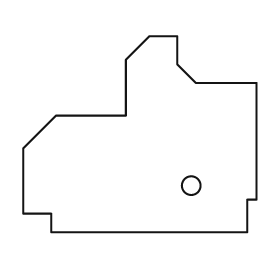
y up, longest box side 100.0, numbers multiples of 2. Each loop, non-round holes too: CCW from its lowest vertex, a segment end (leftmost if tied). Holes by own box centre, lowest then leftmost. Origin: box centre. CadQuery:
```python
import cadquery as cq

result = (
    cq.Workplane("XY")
    .moveTo(-38.0, -42.0)
    .lineTo(46.0, -42.0)
    .lineTo(46.0, -28.0)
    .lineTo(50.0, -28.0)
    .lineTo(50.0, 22.0)
    .lineTo(24.0, 22.0)
    .lineTo(16.0, 30.0)
    .lineTo(16.0, 42.0)
    .lineTo(4.0, 42.0)
    .lineTo(-6.0, 32.0)
    .lineTo(-6.0, 8.0)
    .lineTo(-36.0, 8.0)
    .lineTo(-50.0, -6.0)
    .lineTo(-50.0, -34.0)
    .lineTo(-38.0, -34.0)
    .close()
    .moveTo(22.0, -22.0)
    .circle(4.0)
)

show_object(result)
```